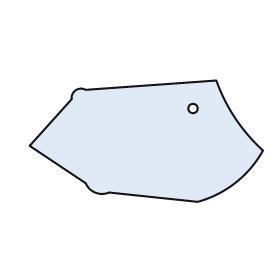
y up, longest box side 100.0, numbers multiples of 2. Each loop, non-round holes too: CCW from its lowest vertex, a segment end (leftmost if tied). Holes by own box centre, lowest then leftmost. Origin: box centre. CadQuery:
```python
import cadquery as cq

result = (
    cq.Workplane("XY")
    .moveTo(22.0, -26.0)
    .threePointArc((38.0, -18.0), (50.0, -4.0))
    .threePointArc((38.0, 10.0), (30.0, 26.0))
    .lineTo(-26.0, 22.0)
    .threePointArc((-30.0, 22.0), (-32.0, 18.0))
    .lineTo(-50.0, -2.0)
    .lineTo(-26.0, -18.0)
    .threePointArc((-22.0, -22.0), (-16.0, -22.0))
    .close()
    .moveTo(20.0, 14.0)
    .circle(2.0)
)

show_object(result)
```